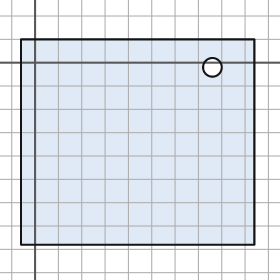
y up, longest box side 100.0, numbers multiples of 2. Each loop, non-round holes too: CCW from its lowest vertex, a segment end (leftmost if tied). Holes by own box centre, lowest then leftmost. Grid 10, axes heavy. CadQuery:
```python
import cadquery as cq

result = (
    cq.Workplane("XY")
    .moveTo(-6.0, -78.0)
    .lineTo(94.0, -78.0)
    .lineTo(94.0, 10.0)
    .lineTo(-6.0, 10.0)
    .close()
    .moveTo(76.0, -2.0)
    .circle(4.0)
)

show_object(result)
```